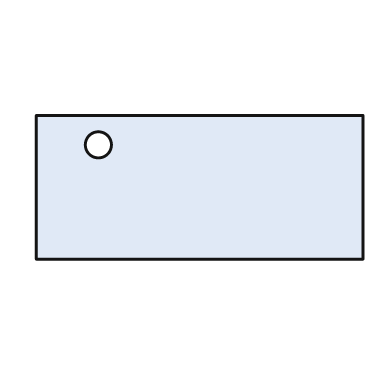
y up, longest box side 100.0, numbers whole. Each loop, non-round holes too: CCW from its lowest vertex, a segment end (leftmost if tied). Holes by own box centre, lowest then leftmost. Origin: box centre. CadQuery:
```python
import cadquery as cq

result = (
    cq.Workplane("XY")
    .moveTo(-50.0, -22.0)
    .lineTo(50.0, -22.0)
    .lineTo(50.0, 22.0)
    .lineTo(-50.0, 22.0)
    .close()
    .moveTo(-31.0, 13.0)
    .circle(4.0)
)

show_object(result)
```